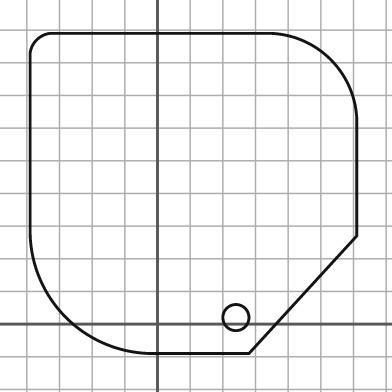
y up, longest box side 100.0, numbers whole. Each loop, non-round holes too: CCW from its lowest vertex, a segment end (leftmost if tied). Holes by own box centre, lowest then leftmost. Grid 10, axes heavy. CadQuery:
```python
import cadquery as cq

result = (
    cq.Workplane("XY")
    .moveTo(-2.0, -9.0)
    .lineTo(28.0, -9.0)
    .lineTo(61.0, 27.0)
    .lineTo(61.0, 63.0)
    .threePointArc((53.0, 81.0), (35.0, 89.0))
    .lineTo(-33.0, 89.0)
    .threePointArc((-37.0, 87.0), (-39.0, 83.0))
    .lineTo(-39.0, 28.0)
    .threePointArc((-28.0, 2.0), (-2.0, -9.0))
    .close()
    .moveTo(24.0, 2.0)
    .circle(4.0)
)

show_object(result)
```